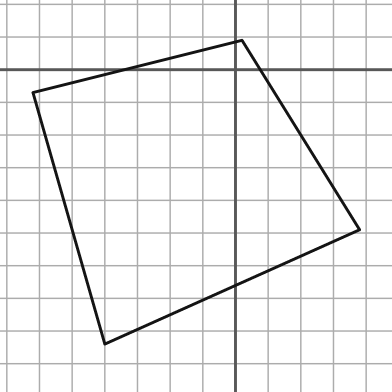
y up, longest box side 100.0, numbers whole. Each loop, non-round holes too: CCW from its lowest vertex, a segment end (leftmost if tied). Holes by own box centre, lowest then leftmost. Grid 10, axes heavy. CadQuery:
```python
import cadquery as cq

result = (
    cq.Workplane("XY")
    .moveTo(-40.0, -84.0)
    .lineTo(38.0, -49.0)
    .lineTo(2.0, 9.0)
    .lineTo(-62.0, -7.0)
    .close()
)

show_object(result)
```